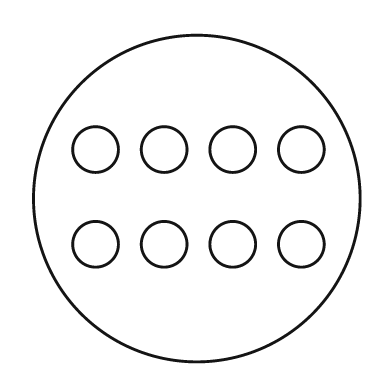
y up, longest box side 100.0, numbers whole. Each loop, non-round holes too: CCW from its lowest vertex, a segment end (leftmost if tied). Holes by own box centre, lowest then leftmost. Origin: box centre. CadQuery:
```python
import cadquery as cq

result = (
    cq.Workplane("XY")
    .moveTo(0.0, 0.0)
    .circle(50.0)
    .moveTo(-31.0, -14.0)
    .circle(7.0)
    .moveTo(-10.0, -14.0)
    .circle(7.0)
    .moveTo(11.0, -14.0)
    .circle(7.0)
    .moveTo(32.0, -14.0)
    .circle(7.0)
    .moveTo(-31.0, 15.0)
    .circle(7.0)
    .moveTo(-10.0, 15.0)
    .circle(7.0)
    .moveTo(11.0, 15.0)
    .circle(7.0)
    .moveTo(32.0, 15.0)
    .circle(7.0)
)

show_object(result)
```